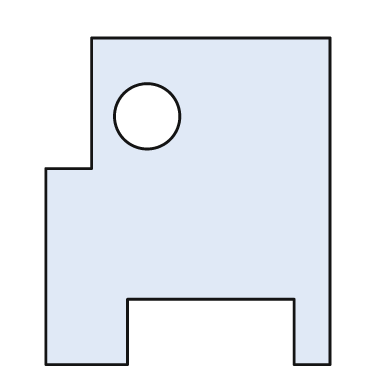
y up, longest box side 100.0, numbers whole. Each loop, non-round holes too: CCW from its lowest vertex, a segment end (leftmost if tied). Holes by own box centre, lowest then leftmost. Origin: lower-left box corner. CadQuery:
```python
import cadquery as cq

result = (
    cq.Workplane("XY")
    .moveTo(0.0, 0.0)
    .lineTo(25.0, 0.0)
    .lineTo(25.0, 20.0)
    .lineTo(76.0, 20.0)
    .lineTo(76.0, 0.0)
    .lineTo(87.0, 0.0)
    .lineTo(87.0, 100.0)
    .lineTo(14.0, 100.0)
    .lineTo(14.0, 60.0)
    .lineTo(0.0, 60.0)
    .close()
    .moveTo(31.0, 76.0)
    .circle(10.0)
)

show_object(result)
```